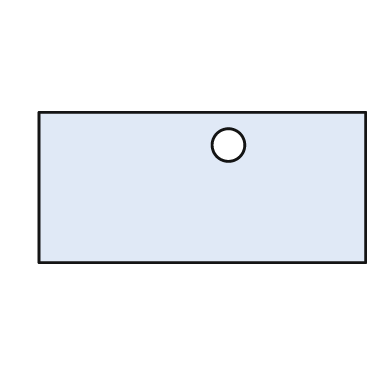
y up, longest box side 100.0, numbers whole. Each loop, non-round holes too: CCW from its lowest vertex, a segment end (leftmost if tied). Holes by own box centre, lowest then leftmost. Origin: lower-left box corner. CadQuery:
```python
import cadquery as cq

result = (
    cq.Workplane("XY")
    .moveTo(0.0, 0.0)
    .lineTo(100.0, 0.0)
    .lineTo(100.0, 46.0)
    .lineTo(0.0, 46.0)
    .close()
    .moveTo(58.0, 36.0)
    .circle(5.0)
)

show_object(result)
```